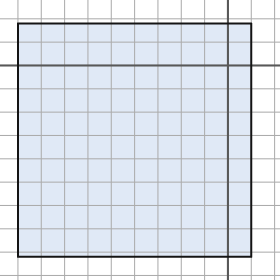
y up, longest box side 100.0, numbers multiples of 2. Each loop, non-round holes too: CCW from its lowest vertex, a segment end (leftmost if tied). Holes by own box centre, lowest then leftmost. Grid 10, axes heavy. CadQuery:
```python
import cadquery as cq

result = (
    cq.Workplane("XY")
    .moveTo(-90.0, -82.0)
    .lineTo(10.0, -82.0)
    .lineTo(10.0, 18.0)
    .lineTo(-90.0, 18.0)
    .close()
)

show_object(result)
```